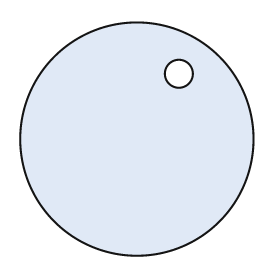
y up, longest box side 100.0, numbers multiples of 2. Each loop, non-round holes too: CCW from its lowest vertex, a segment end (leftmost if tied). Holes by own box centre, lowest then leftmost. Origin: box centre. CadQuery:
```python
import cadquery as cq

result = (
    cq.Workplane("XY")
    .moveTo(0.0, 0.0)
    .circle(50.0)
    .moveTo(18.0, 28.0)
    .circle(6.0)
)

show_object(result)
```